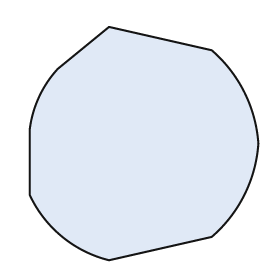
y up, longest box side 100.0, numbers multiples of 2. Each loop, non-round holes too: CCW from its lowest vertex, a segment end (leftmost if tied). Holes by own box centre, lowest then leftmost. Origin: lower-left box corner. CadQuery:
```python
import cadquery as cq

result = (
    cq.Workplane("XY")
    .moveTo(34.0, 0.0)
    .lineTo(78.0, 10.0)
    .threePointArc((92.0, 28.0), (98.0, 50.0))
    .threePointArc((92.0, 72.0), (78.0, 90.0))
    .lineTo(34.0, 100.0)
    .lineTo(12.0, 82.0)
    .threePointArc((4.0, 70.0), (0.0, 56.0))
    .lineTo(0.0, 28.0)
    .threePointArc((14.0, 10.0), (34.0, 0.0))
    .close()
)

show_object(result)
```